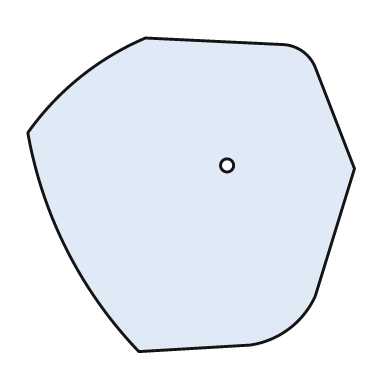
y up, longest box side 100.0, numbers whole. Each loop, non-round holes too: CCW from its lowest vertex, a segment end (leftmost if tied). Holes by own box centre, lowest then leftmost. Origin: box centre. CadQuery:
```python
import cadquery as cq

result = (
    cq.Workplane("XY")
    .moveTo(-16.0, -48.0)
    .lineTo(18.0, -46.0)
    .threePointArc((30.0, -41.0), (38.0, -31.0))
    .lineTo(50.0, 8.0)
    .lineTo(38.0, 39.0)
    .threePointArc((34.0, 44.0), (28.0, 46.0))
    .lineTo(-14.0, 48.0)
    .threePointArc((-34.0, 36.0), (-50.0, 19.0))
    .threePointArc((-38.0, -17.0), (-16.0, -48.0))
    .close()
    .moveTo(11.0, 9.0)
    .circle(2.0)
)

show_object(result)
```